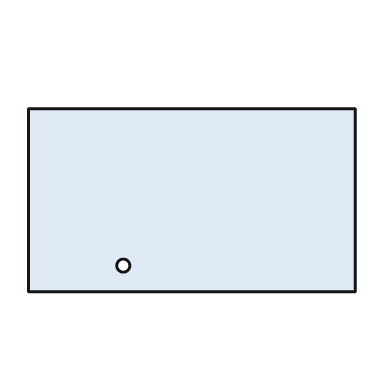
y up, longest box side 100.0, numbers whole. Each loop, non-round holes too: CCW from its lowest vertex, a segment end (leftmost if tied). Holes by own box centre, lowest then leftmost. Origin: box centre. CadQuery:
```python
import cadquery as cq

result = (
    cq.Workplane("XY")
    .moveTo(-50.0, -28.0)
    .lineTo(50.0, -28.0)
    .lineTo(50.0, 28.0)
    .lineTo(-50.0, 28.0)
    .close()
    .moveTo(-21.0, -20.0)
    .circle(2.0)
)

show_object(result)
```